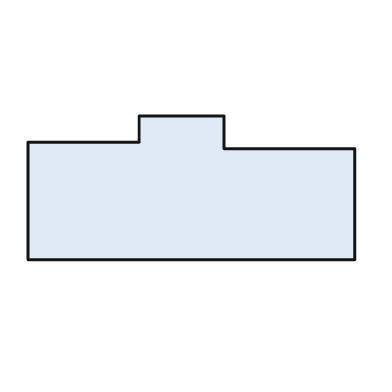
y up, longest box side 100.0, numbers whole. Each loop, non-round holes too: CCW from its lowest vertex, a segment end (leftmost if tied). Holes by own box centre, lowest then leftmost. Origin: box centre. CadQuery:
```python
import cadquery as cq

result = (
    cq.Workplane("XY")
    .moveTo(-50.0, -22.0)
    .lineTo(50.0, -22.0)
    .lineTo(50.0, 12.0)
    .lineTo(10.0, 12.0)
    .lineTo(10.0, 22.0)
    .lineTo(-16.0, 22.0)
    .lineTo(-16.0, 14.0)
    .lineTo(-50.0, 14.0)
    .close()
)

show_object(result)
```